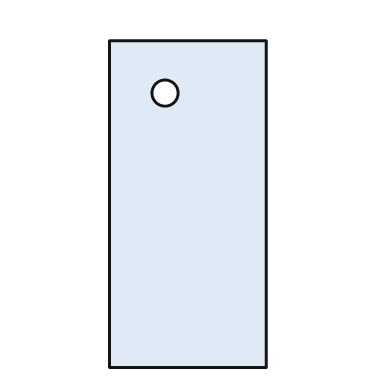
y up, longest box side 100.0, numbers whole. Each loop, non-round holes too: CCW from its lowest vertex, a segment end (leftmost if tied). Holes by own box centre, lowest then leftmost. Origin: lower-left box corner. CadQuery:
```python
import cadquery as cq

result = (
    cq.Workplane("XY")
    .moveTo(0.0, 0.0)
    .lineTo(48.0, 0.0)
    .lineTo(48.0, 100.0)
    .lineTo(0.0, 100.0)
    .close()
    .moveTo(17.0, 84.0)
    .circle(4.0)
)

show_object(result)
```